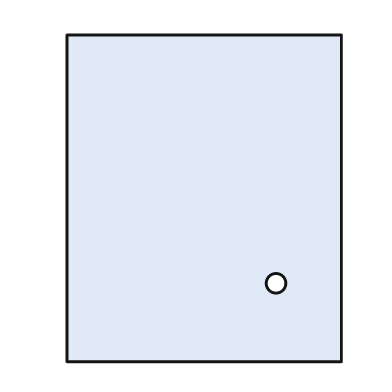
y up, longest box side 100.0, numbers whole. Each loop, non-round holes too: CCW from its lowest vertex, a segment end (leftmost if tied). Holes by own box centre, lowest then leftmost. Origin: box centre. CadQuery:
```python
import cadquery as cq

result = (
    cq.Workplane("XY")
    .moveTo(-42.0, -50.0)
    .lineTo(42.0, -50.0)
    .lineTo(42.0, 50.0)
    .lineTo(-42.0, 50.0)
    .close()
    .moveTo(22.0, -26.0)
    .circle(3.0)
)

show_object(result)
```